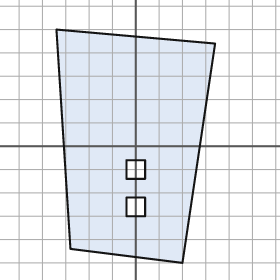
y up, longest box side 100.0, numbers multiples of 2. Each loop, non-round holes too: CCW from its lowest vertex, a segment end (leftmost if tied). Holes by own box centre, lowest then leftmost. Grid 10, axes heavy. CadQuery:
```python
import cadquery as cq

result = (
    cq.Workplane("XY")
    .moveTo(20.0, -50.0)
    .lineTo(34.0, 44.0)
    .lineTo(-34.0, 50.0)
    .lineTo(-28.0, -44.0)
    .close()
    .moveTo(-4.0, -30.0)
    .lineTo(4.0, -30.0)
    .lineTo(4.0, -22.0)
    .lineTo(-4.0, -22.0)
    .close()
    .moveTo(-4.0, -14.0)
    .lineTo(4.0, -14.0)
    .lineTo(4.0, -6.0)
    .lineTo(-4.0, -6.0)
    .close()
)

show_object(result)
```